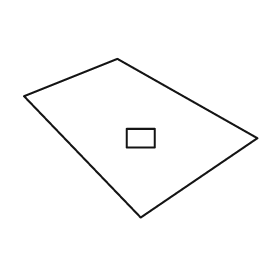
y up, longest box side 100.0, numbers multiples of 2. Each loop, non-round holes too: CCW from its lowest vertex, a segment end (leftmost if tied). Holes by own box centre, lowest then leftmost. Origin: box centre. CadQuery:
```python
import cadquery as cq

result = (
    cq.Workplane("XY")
    .moveTo(0.0, -34.0)
    .lineTo(50.0, 0.0)
    .lineTo(-10.0, 34.0)
    .lineTo(-50.0, 18.0)
    .close()
    .moveTo(-6.0, -4.0)
    .lineTo(6.0, -4.0)
    .lineTo(6.0, 4.0)
    .lineTo(-6.0, 4.0)
    .close()
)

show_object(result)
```